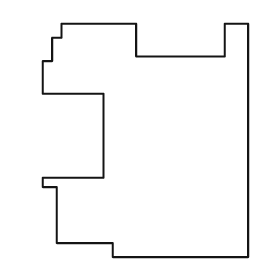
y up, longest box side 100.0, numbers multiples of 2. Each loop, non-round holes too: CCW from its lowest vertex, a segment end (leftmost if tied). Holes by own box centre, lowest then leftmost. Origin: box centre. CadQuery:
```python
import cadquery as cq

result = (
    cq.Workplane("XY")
    .moveTo(-14.0, -50.0)
    .lineTo(44.0, -50.0)
    .lineTo(44.0, 50.0)
    .lineTo(34.0, 50.0)
    .lineTo(34.0, 36.0)
    .lineTo(-4.0, 36.0)
    .lineTo(-4.0, 50.0)
    .lineTo(-36.0, 50.0)
    .lineTo(-36.0, 44.0)
    .lineTo(-40.0, 44.0)
    .lineTo(-40.0, 34.0)
    .lineTo(-44.0, 34.0)
    .lineTo(-44.0, 20.0)
    .lineTo(-18.0, 20.0)
    .lineTo(-18.0, -16.0)
    .lineTo(-44.0, -16.0)
    .lineTo(-44.0, -20.0)
    .lineTo(-38.0, -20.0)
    .lineTo(-38.0, -44.0)
    .lineTo(-14.0, -44.0)
    .close()
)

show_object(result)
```